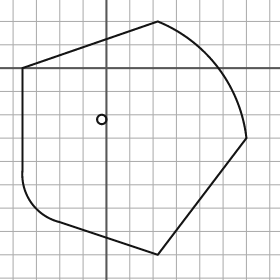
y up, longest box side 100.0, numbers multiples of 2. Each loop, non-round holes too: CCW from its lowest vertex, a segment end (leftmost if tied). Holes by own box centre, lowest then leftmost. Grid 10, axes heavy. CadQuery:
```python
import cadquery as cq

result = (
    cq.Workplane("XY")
    .moveTo(22.0, -80.0)
    .lineTo(60.0, -30.0)
    .threePointArc((48.0, 0.0), (22.0, 20.0))
    .lineTo(-36.0, 0.0)
    .lineTo(-36.0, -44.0)
    .threePointArc((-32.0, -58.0), (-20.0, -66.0))
    .close()
    .moveTo(-2.0, -22.0)
    .circle(2.0)
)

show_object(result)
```